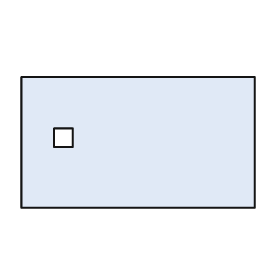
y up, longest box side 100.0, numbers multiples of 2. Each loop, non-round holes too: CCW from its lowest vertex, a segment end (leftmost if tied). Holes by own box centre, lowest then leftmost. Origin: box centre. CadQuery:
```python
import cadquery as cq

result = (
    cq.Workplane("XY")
    .moveTo(-50.0, -28.0)
    .lineTo(50.0, -28.0)
    .lineTo(50.0, 28.0)
    .lineTo(-50.0, 28.0)
    .close()
    .moveTo(-36.0, -2.0)
    .lineTo(-28.0, -2.0)
    .lineTo(-28.0, 6.0)
    .lineTo(-36.0, 6.0)
    .close()
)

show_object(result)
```